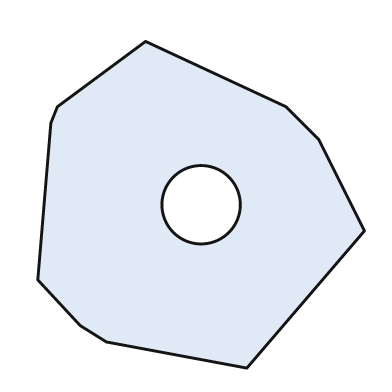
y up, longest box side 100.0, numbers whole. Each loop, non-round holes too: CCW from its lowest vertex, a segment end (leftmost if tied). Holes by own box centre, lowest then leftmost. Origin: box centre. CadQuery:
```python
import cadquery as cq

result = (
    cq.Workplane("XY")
    .moveTo(14.0, -50.0)
    .lineTo(50.0, -8.0)
    .lineTo(36.0, 20.0)
    .lineTo(26.0, 30.0)
    .lineTo(-17.0, 50.0)
    .lineTo(-44.0, 30.0)
    .lineTo(-46.0, 25.0)
    .lineTo(-50.0, -23.0)
    .lineTo(-37.0, -37.0)
    .lineTo(-29.0, -42.0)
    .close()
    .moveTo(0.0, 0.0)
    .circle(12.0)
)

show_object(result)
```